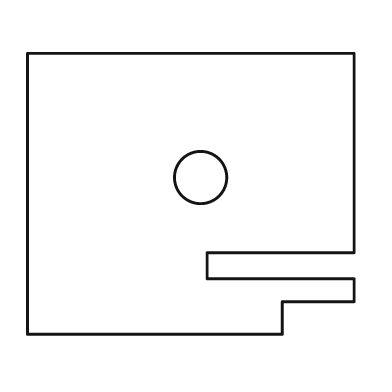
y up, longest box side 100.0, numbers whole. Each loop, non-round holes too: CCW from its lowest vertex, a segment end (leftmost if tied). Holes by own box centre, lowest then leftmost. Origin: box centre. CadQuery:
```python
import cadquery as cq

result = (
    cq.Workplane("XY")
    .moveTo(-50.0, -43.0)
    .lineTo(28.0, -43.0)
    .lineTo(28.0, -33.0)
    .lineTo(50.0, -33.0)
    .lineTo(50.0, -26.0)
    .lineTo(5.0, -26.0)
    .lineTo(5.0, -18.0)
    .lineTo(50.0, -18.0)
    .lineTo(50.0, 43.0)
    .lineTo(-50.0, 43.0)
    .close()
    .moveTo(3.0, 5.0)
    .circle(8.0)
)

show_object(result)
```